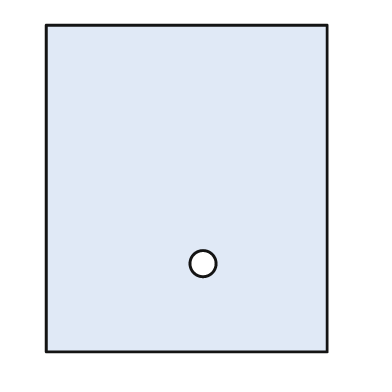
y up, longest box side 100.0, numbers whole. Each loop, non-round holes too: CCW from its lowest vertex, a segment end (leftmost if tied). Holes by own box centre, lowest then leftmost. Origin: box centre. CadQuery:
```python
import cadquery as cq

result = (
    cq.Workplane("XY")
    .moveTo(-43.0, -50.0)
    .lineTo(43.0, -50.0)
    .lineTo(43.0, 50.0)
    .lineTo(-43.0, 50.0)
    .close()
    .moveTo(5.0, -23.0)
    .circle(4.0)
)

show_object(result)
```